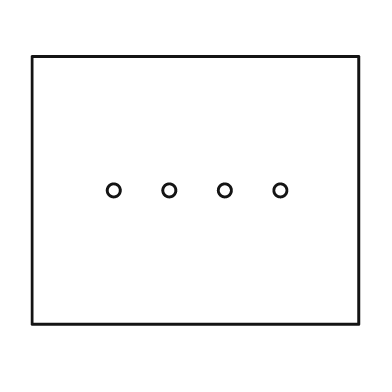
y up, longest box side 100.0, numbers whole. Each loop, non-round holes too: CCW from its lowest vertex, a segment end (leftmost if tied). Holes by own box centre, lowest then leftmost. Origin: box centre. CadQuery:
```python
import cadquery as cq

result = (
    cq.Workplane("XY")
    .moveTo(-50.0, -41.0)
    .lineTo(50.0, -41.0)
    .lineTo(50.0, 41.0)
    .lineTo(-50.0, 41.0)
    .close()
    .moveTo(-25.0, 0.0)
    .circle(2.0)
    .moveTo(-8.0, 0.0)
    .circle(2.0)
    .moveTo(9.0, 0.0)
    .circle(2.0)
    .moveTo(26.0, 0.0)
    .circle(2.0)
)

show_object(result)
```